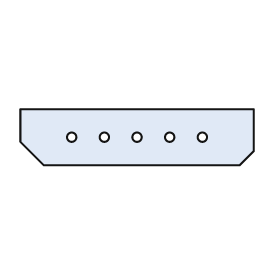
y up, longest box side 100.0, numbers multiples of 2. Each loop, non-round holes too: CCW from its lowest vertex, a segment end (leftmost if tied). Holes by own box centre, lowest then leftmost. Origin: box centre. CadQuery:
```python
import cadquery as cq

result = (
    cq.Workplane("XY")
    .moveTo(-40.0, -12.0)
    .lineTo(44.0, -12.0)
    .lineTo(50.0, -6.0)
    .lineTo(50.0, 12.0)
    .lineTo(-50.0, 12.0)
    .lineTo(-50.0, -2.0)
    .close()
    .moveTo(-28.0, 0.0)
    .circle(2.0)
    .moveTo(-14.0, 0.0)
    .circle(2.0)
    .moveTo(0.0, 0.0)
    .circle(2.0)
    .moveTo(14.0, 0.0)
    .circle(2.0)
    .moveTo(28.0, 0.0)
    .circle(2.0)
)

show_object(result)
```